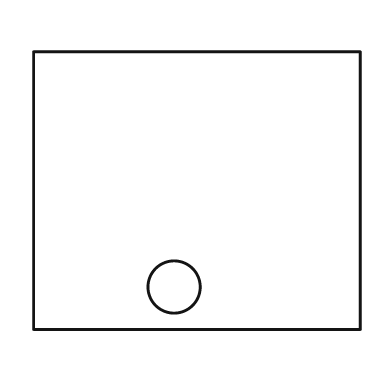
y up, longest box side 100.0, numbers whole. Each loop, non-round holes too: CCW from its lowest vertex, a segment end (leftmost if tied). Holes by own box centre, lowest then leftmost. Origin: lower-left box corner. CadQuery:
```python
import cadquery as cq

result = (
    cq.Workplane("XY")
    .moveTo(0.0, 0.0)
    .lineTo(100.0, 0.0)
    .lineTo(100.0, 85.0)
    .lineTo(0.0, 85.0)
    .close()
    .moveTo(43.0, 13.0)
    .circle(8.0)
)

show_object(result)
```